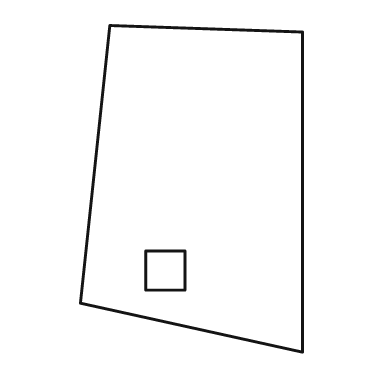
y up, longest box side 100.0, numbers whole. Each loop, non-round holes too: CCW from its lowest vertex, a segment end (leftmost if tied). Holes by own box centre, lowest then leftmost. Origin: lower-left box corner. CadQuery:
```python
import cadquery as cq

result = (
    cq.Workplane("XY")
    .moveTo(68.0, 0.0)
    .lineTo(68.0, 98.0)
    .lineTo(9.0, 100.0)
    .lineTo(0.0, 15.0)
    .close()
    .moveTo(20.0, 19.0)
    .lineTo(32.0, 19.0)
    .lineTo(32.0, 31.0)
    .lineTo(20.0, 31.0)
    .close()
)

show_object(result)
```